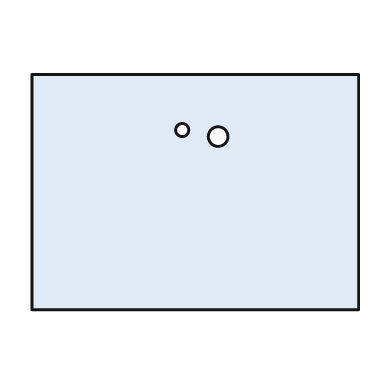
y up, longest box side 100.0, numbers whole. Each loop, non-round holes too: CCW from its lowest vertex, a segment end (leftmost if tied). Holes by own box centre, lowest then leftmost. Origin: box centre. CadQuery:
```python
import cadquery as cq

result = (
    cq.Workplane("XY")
    .moveTo(-50.0, -36.0)
    .lineTo(50.0, -36.0)
    .lineTo(50.0, 36.0)
    .lineTo(-50.0, 36.0)
    .close()
    .moveTo(7.0, 17.0)
    .circle(3.0)
    .moveTo(-4.0, 19.0)
    .circle(2.0)
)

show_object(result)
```